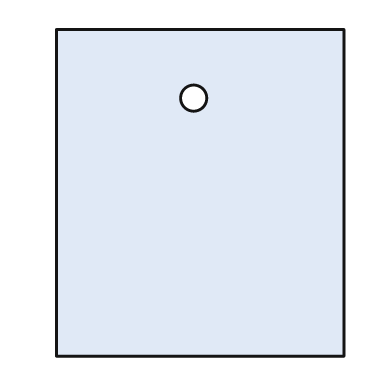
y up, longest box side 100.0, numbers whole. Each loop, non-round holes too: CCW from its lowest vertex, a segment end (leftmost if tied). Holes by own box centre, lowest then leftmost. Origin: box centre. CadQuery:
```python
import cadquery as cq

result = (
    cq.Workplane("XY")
    .moveTo(-44.0, -50.0)
    .lineTo(44.0, -50.0)
    .lineTo(44.0, 50.0)
    .lineTo(-44.0, 50.0)
    .close()
    .moveTo(-2.0, 29.0)
    .circle(4.0)
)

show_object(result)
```